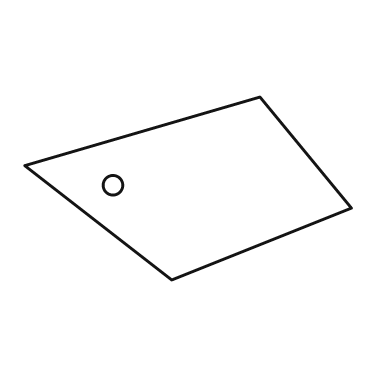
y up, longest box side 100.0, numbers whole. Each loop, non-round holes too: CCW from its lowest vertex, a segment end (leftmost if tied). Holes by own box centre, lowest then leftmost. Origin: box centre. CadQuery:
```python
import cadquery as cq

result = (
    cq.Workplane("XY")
    .moveTo(-5.0, -28.0)
    .lineTo(50.0, -6.0)
    .lineTo(22.0, 28.0)
    .lineTo(-50.0, 7.0)
    .close()
    .moveTo(-23.0, 1.0)
    .circle(3.0)
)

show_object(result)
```